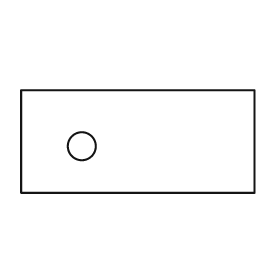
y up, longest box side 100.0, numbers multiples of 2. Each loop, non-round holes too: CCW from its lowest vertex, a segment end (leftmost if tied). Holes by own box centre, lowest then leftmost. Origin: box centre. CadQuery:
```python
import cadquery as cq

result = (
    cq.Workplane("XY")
    .moveTo(-50.0, -22.0)
    .lineTo(50.0, -22.0)
    .lineTo(50.0, 22.0)
    .lineTo(-50.0, 22.0)
    .close()
    .moveTo(-24.0, -2.0)
    .circle(6.0)
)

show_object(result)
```